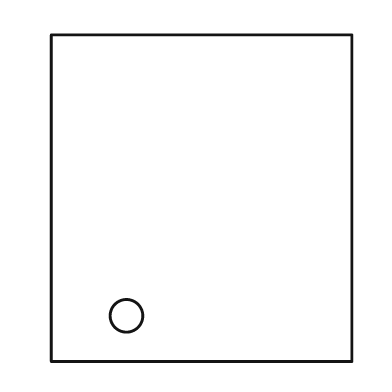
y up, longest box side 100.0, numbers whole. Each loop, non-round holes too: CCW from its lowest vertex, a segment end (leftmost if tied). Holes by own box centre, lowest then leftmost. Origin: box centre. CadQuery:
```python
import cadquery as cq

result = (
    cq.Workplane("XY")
    .moveTo(-46.0, -50.0)
    .lineTo(46.0, -50.0)
    .lineTo(46.0, 50.0)
    .lineTo(-46.0, 50.0)
    .close()
    .moveTo(-23.0, -36.0)
    .circle(5.0)
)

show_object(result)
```